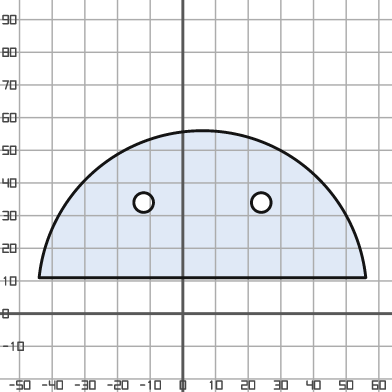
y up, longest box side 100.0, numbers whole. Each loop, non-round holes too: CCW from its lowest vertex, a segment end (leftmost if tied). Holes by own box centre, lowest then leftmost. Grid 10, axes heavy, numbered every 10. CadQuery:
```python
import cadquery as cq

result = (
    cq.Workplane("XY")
    .moveTo(-44.0, 11.0)
    .lineTo(56.0, 11.0)
    .threePointArc((6.0, 56.0), (-44.0, 11.0))
    .close()
    .moveTo(-12.0, 34.0)
    .circle(3.0)
    .moveTo(24.0, 34.0)
    .circle(3.0)
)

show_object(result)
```